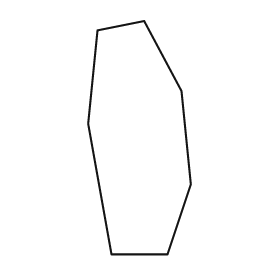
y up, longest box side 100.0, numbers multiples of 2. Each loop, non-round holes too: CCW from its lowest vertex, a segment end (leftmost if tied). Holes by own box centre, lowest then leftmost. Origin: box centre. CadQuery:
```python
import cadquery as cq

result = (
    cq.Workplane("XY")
    .moveTo(-12.0, -50.0)
    .lineTo(12.0, -50.0)
    .lineTo(22.0, -20.0)
    .lineTo(18.0, 20.0)
    .lineTo(2.0, 50.0)
    .lineTo(-18.0, 46.0)
    .lineTo(-22.0, 6.0)
    .close()
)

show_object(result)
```